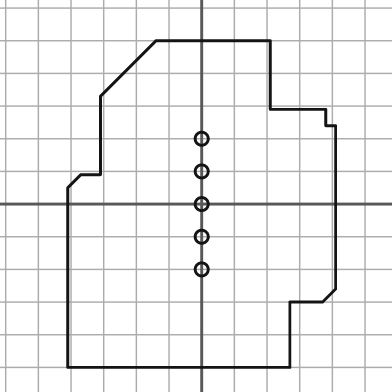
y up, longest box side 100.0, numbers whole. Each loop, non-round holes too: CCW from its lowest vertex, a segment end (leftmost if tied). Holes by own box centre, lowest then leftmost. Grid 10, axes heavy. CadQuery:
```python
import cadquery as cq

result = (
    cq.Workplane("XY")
    .moveTo(-41.0, -50.0)
    .lineTo(27.0, -50.0)
    .lineTo(27.0, -30.0)
    .lineTo(37.0, -30.0)
    .lineTo(41.0, -26.0)
    .lineTo(41.0, 24.0)
    .lineTo(38.0, 24.0)
    .lineTo(38.0, 29.0)
    .lineTo(21.0, 29.0)
    .lineTo(21.0, 50.0)
    .lineTo(-14.0, 50.0)
    .lineTo(-31.0, 33.0)
    .lineTo(-31.0, 9.0)
    .lineTo(-37.0, 9.0)
    .lineTo(-41.0, 5.0)
    .close()
    .moveTo(0.0, -20.0)
    .circle(2.0)
    .moveTo(0.0, -10.0)
    .circle(2.0)
    .moveTo(0.0, 0.0)
    .circle(2.0)
    .moveTo(0.0, 10.0)
    .circle(2.0)
    .moveTo(0.0, 20.0)
    .circle(2.0)
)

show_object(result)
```